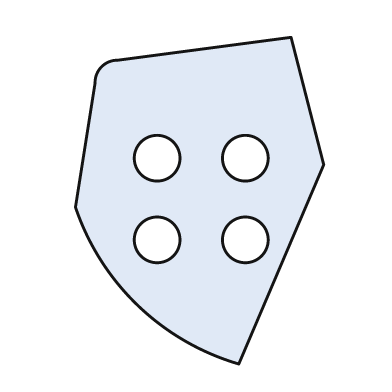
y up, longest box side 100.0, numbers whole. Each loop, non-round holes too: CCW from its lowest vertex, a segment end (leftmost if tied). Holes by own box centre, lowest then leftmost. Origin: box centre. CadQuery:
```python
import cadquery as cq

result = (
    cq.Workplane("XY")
    .moveTo(12.0, -50.0)
    .lineTo(38.0, 11.0)
    .lineTo(28.0, 50.0)
    .lineTo(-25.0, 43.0)
    .threePointArc((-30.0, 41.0), (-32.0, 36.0))
    .lineTo(-38.0, -2.0)
    .threePointArc((-19.0, -32.0), (12.0, -50.0))
    .close()
    .moveTo(-13.0, -12.0)
    .circle(7.0)
    .moveTo(14.0, -12.0)
    .circle(7.0)
    .moveTo(-13.0, 13.0)
    .circle(7.0)
    .moveTo(14.0, 13.0)
    .circle(7.0)
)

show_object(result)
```